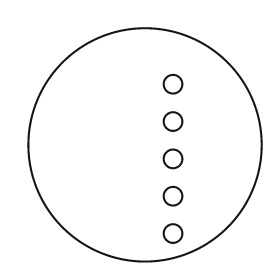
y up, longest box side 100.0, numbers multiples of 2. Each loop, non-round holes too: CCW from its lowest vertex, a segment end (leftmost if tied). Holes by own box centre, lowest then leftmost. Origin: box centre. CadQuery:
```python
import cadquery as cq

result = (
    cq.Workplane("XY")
    .moveTo(0.0, 0.0)
    .circle(50.0)
    .moveTo(12.0, -38.0)
    .circle(4.0)
    .moveTo(12.0, -22.0)
    .circle(4.0)
    .moveTo(12.0, -6.0)
    .circle(4.0)
    .moveTo(12.0, 10.0)
    .circle(4.0)
    .moveTo(12.0, 26.0)
    .circle(4.0)
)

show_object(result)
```